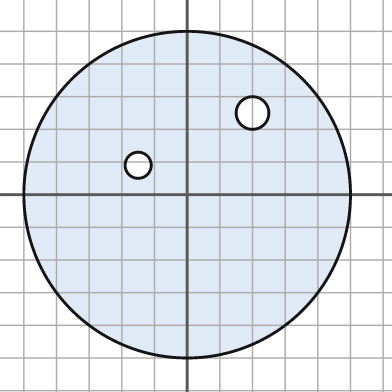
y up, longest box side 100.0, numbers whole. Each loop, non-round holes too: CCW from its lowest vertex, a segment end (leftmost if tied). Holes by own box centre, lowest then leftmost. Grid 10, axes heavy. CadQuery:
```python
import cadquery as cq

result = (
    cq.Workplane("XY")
    .moveTo(0.0, 0.0)
    .circle(50.0)
    .moveTo(-15.0, 9.0)
    .circle(4.0)
    .moveTo(20.0, 25.0)
    .circle(5.0)
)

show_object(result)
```